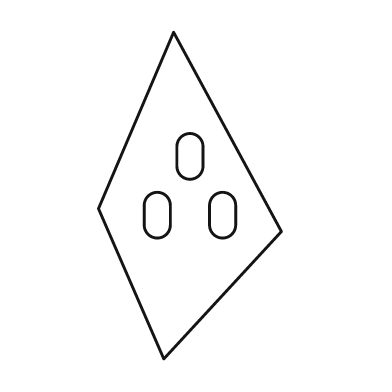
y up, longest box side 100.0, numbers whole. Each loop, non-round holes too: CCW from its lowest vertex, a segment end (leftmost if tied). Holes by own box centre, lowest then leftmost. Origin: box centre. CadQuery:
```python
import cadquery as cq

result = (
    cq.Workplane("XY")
    .moveTo(-8.0, -50.0)
    .lineTo(28.0, -11.0)
    .lineTo(-5.0, 50.0)
    .lineTo(-28.0, -4.0)
    .close()
    .moveTo(-14.0, -9.0)
    .threePointArc((-10.0, -13.0), (-6.0, -9.0))
    .lineTo(-6.0, -3.0)
    .threePointArc((-10.0, 1.0), (-14.0, -3.0))
    .close()
    .moveTo(6.0, -9.0)
    .threePointArc((10.0, -13.0), (14.0, -9.0))
    .lineTo(14.0, -3.0)
    .threePointArc((10.0, 1.0), (6.0, -3.0))
    .close()
    .moveTo(-4.0, 9.0)
    .threePointArc((0.0, 5.0), (4.0, 9.0))
    .lineTo(4.0, 15.0)
    .threePointArc((0.0, 19.0), (-4.0, 15.0))
    .close()
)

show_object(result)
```